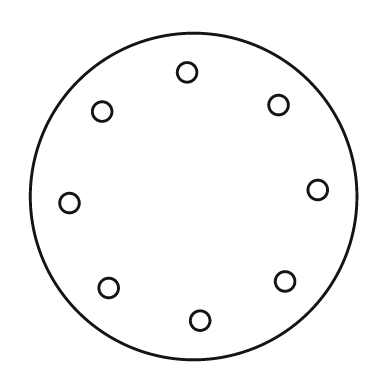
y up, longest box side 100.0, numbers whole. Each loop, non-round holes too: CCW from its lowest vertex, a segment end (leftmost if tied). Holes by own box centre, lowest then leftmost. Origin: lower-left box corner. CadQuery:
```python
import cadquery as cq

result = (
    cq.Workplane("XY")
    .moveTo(50.0, 50.0)
    .circle(50.0)
    .moveTo(52.0, 12.0)
    .circle(3.0)
    .moveTo(24.0, 22.0)
    .circle(3.0)
    .moveTo(78.0, 24.0)
    .circle(3.0)
    .moveTo(12.0, 48.0)
    .circle(3.0)
    .moveTo(88.0, 52.0)
    .circle(3.0)
    .moveTo(22.0, 76.0)
    .circle(3.0)
    .moveTo(76.0, 78.0)
    .circle(3.0)
    .moveTo(48.0, 88.0)
    .circle(3.0)
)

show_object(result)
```